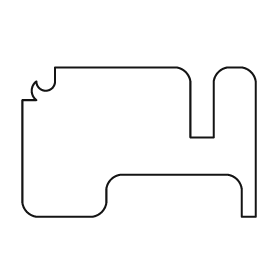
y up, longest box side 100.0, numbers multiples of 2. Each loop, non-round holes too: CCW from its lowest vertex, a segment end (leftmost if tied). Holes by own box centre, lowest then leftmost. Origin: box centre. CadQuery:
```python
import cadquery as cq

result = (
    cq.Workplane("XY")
    .moveTo(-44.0, -32.0)
    .lineTo(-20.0, -32.0)
    .threePointArc((-16.0, -30.0), (-14.0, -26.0))
    .lineTo(-14.0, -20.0)
    .threePointArc((-12.0, -16.0), (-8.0, -14.0))
    .lineTo(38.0, -14.0)
    .threePointArc((42.0, -16.0), (44.0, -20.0))
    .lineTo(44.0, -32.0)
    .lineTo(50.0, -32.0)
    .lineTo(50.0, 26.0)
    .threePointArc((48.0, 30.0), (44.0, 32.0))
    .lineTo(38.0, 32.0)
    .threePointArc((34.0, 30.0), (32.0, 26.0))
    .lineTo(32.0, 2.0)
    .lineTo(22.0, 2.0)
    .lineTo(22.0, 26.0)
    .threePointArc((20.0, 30.0), (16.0, 32.0))
    .lineTo(-36.0, 32.0)
    .lineTo(-36.0, 26.0)
    .threePointArc((-40.0, 22.0), (-44.0, 26.0))
    .threePointArc((-46.0, 22.0), (-44.0, 18.0))
    .lineTo(-50.0, 18.0)
    .lineTo(-50.0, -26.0)
    .threePointArc((-48.0, -30.0), (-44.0, -32.0))
    .close()
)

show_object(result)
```